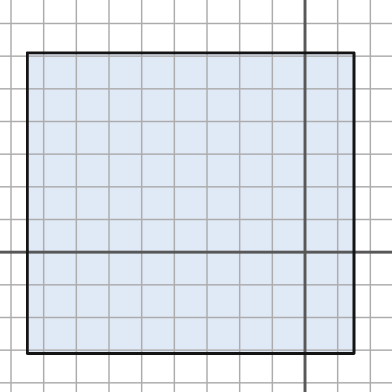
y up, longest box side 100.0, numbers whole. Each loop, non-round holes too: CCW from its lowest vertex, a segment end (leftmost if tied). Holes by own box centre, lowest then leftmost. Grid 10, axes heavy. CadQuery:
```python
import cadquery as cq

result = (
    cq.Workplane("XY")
    .moveTo(-85.0, -31.0)
    .lineTo(15.0, -31.0)
    .lineTo(15.0, 61.0)
    .lineTo(-85.0, 61.0)
    .close()
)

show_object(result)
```